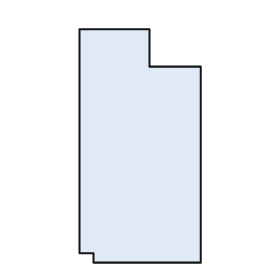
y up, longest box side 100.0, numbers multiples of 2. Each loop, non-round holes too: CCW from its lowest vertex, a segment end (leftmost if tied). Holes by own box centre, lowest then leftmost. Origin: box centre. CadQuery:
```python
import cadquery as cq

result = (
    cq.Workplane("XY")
    .moveTo(-20.0, -50.0)
    .lineTo(26.0, -50.0)
    .lineTo(26.0, 34.0)
    .lineTo(4.0, 34.0)
    .lineTo(4.0, 50.0)
    .lineTo(-26.0, 50.0)
    .lineTo(-26.0, -46.0)
    .lineTo(-20.0, -46.0)
    .close()
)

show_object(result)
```